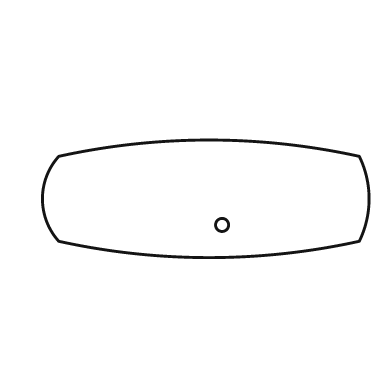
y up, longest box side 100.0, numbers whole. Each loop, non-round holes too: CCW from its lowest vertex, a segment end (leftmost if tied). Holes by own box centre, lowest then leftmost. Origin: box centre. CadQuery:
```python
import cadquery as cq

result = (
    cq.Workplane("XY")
    .moveTo(-45.0, -13.0)
    .threePointArc((1.0, -18.0), (47.0, -13.0))
    .threePointArc((50.0, 0.0), (47.0, 13.0))
    .threePointArc((1.0, 18.0), (-45.0, 13.0))
    .threePointArc((-50.0, 0.0), (-45.0, -13.0))
    .close()
    .moveTo(5.0, -8.0)
    .circle(2.0)
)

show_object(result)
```